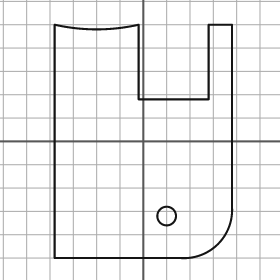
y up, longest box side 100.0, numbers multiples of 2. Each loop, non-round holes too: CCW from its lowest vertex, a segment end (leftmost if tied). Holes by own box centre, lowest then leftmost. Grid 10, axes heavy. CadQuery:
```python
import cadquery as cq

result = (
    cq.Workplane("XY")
    .moveTo(-38.0, -50.0)
    .lineTo(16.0, -50.0)
    .threePointArc((32.0, -44.0), (38.0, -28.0))
    .lineTo(38.0, 50.0)
    .lineTo(28.0, 50.0)
    .lineTo(28.0, 18.0)
    .lineTo(-2.0, 18.0)
    .lineTo(-2.0, 50.0)
    .threePointArc((-20.0, 48.0), (-38.0, 50.0))
    .close()
    .moveTo(10.0, -32.0)
    .circle(4.0)
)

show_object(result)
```